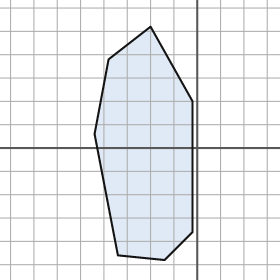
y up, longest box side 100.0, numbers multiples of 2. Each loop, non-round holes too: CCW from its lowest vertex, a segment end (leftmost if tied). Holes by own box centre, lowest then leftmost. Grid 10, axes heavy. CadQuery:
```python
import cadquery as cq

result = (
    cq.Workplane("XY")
    .moveTo(-14.0, -48.0)
    .lineTo(-2.0, -36.0)
    .lineTo(-2.0, 20.0)
    .lineTo(-20.0, 52.0)
    .lineTo(-38.0, 38.0)
    .lineTo(-44.0, 6.0)
    .lineTo(-34.0, -46.0)
    .close()
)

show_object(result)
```